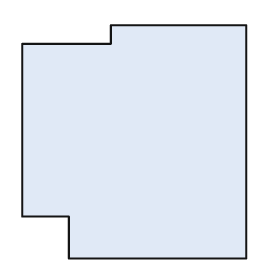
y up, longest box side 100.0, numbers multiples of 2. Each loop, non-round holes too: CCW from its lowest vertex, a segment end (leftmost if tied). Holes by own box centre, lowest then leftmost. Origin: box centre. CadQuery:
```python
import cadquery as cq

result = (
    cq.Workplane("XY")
    .moveTo(-28.0, -50.0)
    .lineTo(48.0, -50.0)
    .lineTo(48.0, 50.0)
    .lineTo(-10.0, 50.0)
    .lineTo(-10.0, 42.0)
    .lineTo(-48.0, 42.0)
    .lineTo(-48.0, -32.0)
    .lineTo(-28.0, -32.0)
    .close()
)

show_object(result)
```